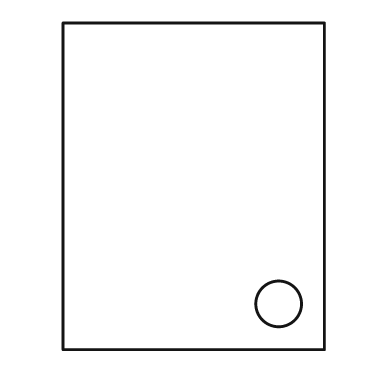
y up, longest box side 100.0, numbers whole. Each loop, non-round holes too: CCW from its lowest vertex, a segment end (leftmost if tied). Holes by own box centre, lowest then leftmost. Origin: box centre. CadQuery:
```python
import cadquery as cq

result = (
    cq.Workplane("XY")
    .moveTo(-40.0, -50.0)
    .lineTo(40.0, -50.0)
    .lineTo(40.0, 50.0)
    .lineTo(-40.0, 50.0)
    .close()
    .moveTo(26.0, -36.0)
    .circle(7.0)
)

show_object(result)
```